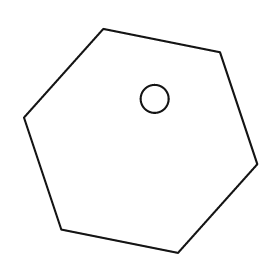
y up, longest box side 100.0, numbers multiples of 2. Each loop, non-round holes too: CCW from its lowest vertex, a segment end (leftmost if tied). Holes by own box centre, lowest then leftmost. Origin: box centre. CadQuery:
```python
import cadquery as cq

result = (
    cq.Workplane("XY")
    .moveTo(16.0, -48.0)
    .lineTo(50.0, -10.0)
    .lineTo(34.0, 38.0)
    .lineTo(-16.0, 48.0)
    .lineTo(-50.0, 10.0)
    .lineTo(-34.0, -38.0)
    .close()
    .moveTo(6.0, 18.0)
    .circle(6.0)
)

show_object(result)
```